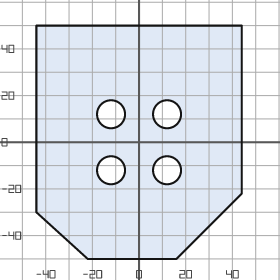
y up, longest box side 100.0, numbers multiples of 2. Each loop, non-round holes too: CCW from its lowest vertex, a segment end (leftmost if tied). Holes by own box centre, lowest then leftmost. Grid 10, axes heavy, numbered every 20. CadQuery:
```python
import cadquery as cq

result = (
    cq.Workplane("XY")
    .moveTo(-22.0, -50.0)
    .lineTo(16.0, -50.0)
    .lineTo(44.0, -22.0)
    .lineTo(44.0, 50.0)
    .lineTo(-44.0, 50.0)
    .lineTo(-44.0, -30.0)
    .close()
    .moveTo(-12.0, -12.0)
    .circle(6.0)
    .moveTo(12.0, -12.0)
    .circle(6.0)
    .moveTo(-12.0, 12.0)
    .circle(6.0)
    .moveTo(12.0, 12.0)
    .circle(6.0)
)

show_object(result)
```